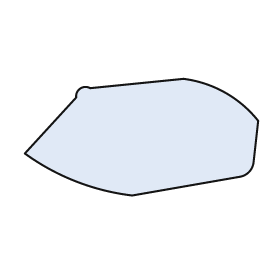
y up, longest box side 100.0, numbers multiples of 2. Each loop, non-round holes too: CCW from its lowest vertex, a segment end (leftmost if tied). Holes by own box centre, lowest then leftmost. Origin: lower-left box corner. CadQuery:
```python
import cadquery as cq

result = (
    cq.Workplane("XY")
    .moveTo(46.0, 0.0)
    .lineTo(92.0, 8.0)
    .threePointArc((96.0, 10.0), (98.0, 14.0))
    .lineTo(100.0, 32.0)
    .threePointArc((86.0, 44.0), (68.0, 50.0))
    .lineTo(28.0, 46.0)
    .threePointArc((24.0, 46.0), (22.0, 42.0))
    .lineTo(0.0, 18.0)
    .threePointArc((22.0, 6.0), (46.0, 0.0))
    .close()
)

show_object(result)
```